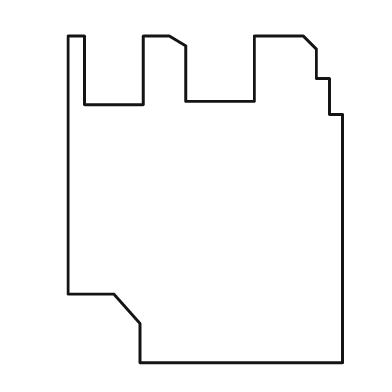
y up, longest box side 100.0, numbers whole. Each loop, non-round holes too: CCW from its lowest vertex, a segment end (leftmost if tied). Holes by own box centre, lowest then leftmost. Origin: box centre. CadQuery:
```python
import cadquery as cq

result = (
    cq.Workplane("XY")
    .moveTo(-20.0, -50.0)
    .lineTo(42.0, -50.0)
    .lineTo(42.0, 26.0)
    .lineTo(38.0, 26.0)
    .lineTo(38.0, 37.0)
    .lineTo(34.0, 37.0)
    .lineTo(34.0, 46.0)
    .lineTo(30.0, 50.0)
    .lineTo(15.0, 50.0)
    .lineTo(15.0, 30.0)
    .lineTo(-6.0, 30.0)
    .lineTo(-6.0, 47.0)
    .lineTo(-11.0, 50.0)
    .lineTo(-19.0, 50.0)
    .lineTo(-19.0, 29.0)
    .lineTo(-37.0, 29.0)
    .lineTo(-37.0, 50.0)
    .lineTo(-42.0, 50.0)
    .lineTo(-42.0, -29.0)
    .lineTo(-28.0, -29.0)
    .lineTo(-20.0, -38.0)
    .close()
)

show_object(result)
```